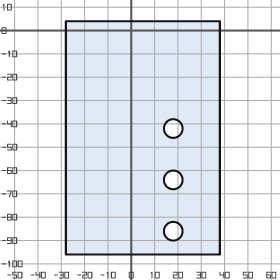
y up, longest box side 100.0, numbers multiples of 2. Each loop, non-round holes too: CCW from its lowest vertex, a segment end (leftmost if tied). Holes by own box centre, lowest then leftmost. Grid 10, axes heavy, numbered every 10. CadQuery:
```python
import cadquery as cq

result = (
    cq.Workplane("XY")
    .moveTo(-28.0, -96.0)
    .lineTo(38.0, -96.0)
    .lineTo(38.0, 4.0)
    .lineTo(-28.0, 4.0)
    .close()
    .moveTo(18.0, -86.0)
    .circle(4.0)
    .moveTo(18.0, -64.0)
    .circle(4.0)
    .moveTo(18.0, -42.0)
    .circle(4.0)
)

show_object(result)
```